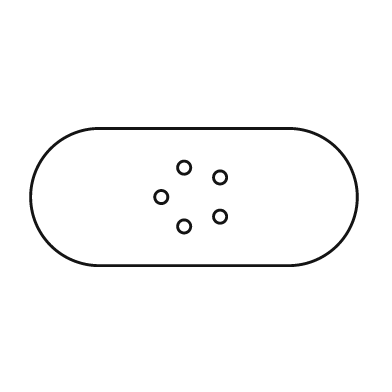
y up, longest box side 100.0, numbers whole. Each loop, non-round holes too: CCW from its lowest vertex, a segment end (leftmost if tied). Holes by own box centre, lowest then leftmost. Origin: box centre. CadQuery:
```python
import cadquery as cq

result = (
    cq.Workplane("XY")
    .moveTo(-29.0, -21.0)
    .lineTo(29.0, -21.0)
    .threePointArc((50.0, 0.0), (29.0, 21.0))
    .lineTo(-29.0, 21.0)
    .threePointArc((-50.0, 0.0), (-29.0, -21.0))
    .close()
    .moveTo(-3.0, -9.0)
    .circle(2.0)
    .moveTo(8.0, -6.0)
    .circle(2.0)
    .moveTo(-10.0, 0.0)
    .circle(2.0)
    .moveTo(8.0, 6.0)
    .circle(2.0)
    .moveTo(-3.0, 9.0)
    .circle(2.0)
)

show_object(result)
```